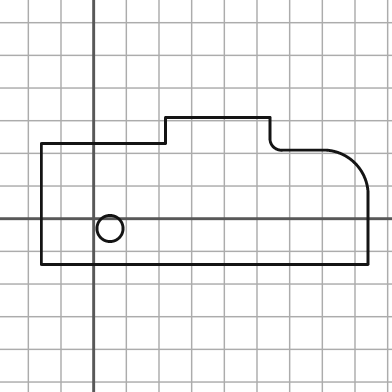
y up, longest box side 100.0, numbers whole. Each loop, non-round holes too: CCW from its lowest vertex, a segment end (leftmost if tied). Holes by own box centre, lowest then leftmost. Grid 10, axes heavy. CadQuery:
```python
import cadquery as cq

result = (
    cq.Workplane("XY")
    .moveTo(-16.0, -14.0)
    .lineTo(84.0, -14.0)
    .lineTo(84.0, 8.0)
    .threePointArc((80.0, 17.0), (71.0, 21.0))
    .lineTo(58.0, 21.0)
    .threePointArc((55.0, 22.0), (54.0, 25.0))
    .lineTo(54.0, 31.0)
    .lineTo(22.0, 31.0)
    .lineTo(22.0, 23.0)
    .lineTo(-16.0, 23.0)
    .close()
    .moveTo(5.0, -3.0)
    .circle(4.0)
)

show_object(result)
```